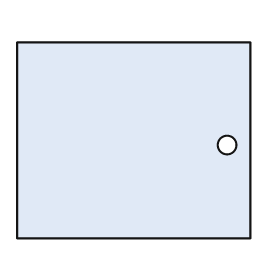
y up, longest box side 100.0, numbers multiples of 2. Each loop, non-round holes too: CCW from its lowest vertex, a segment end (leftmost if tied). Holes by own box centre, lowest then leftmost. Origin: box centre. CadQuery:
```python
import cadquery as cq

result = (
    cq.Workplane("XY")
    .moveTo(-50.0, -42.0)
    .lineTo(50.0, -42.0)
    .lineTo(50.0, 42.0)
    .lineTo(-50.0, 42.0)
    .close()
    .moveTo(40.0, -2.0)
    .circle(4.0)
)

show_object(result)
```